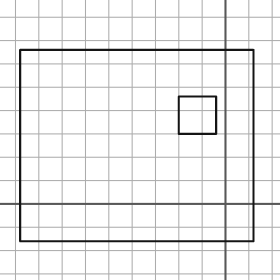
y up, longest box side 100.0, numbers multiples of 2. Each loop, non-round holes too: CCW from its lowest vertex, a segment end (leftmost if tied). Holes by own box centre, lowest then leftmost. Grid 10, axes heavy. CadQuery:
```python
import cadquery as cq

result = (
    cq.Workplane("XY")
    .moveTo(-88.0, -16.0)
    .lineTo(12.0, -16.0)
    .lineTo(12.0, 66.0)
    .lineTo(-88.0, 66.0)
    .close()
    .moveTo(-20.0, 30.0)
    .lineTo(-4.0, 30.0)
    .lineTo(-4.0, 46.0)
    .lineTo(-20.0, 46.0)
    .close()
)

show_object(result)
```